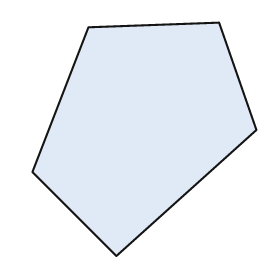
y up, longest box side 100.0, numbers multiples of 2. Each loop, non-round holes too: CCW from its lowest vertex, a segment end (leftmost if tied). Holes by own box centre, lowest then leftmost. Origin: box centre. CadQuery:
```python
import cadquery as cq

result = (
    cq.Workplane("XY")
    .moveTo(-12.0, -50.0)
    .lineTo(48.0, 4.0)
    .lineTo(32.0, 50.0)
    .lineTo(-24.0, 48.0)
    .lineTo(-48.0, -14.0)
    .close()
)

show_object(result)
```